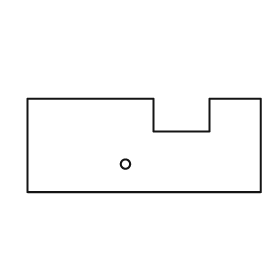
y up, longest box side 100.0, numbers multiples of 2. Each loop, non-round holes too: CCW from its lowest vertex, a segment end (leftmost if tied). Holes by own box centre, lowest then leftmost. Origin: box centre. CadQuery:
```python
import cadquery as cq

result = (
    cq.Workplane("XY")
    .moveTo(-50.0, -20.0)
    .lineTo(50.0, -20.0)
    .lineTo(50.0, 20.0)
    .lineTo(28.0, 20.0)
    .lineTo(28.0, 6.0)
    .lineTo(4.0, 6.0)
    .lineTo(4.0, 20.0)
    .lineTo(-50.0, 20.0)
    .close()
    .moveTo(-8.0, -8.0)
    .circle(2.0)
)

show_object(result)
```